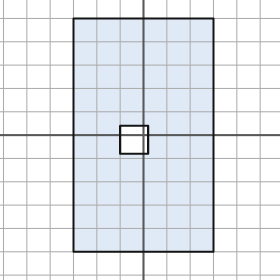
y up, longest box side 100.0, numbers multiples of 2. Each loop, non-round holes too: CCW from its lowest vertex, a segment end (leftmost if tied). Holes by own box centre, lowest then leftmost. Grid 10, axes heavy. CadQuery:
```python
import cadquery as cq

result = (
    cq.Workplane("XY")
    .moveTo(-30.0, -50.0)
    .lineTo(30.0, -50.0)
    .lineTo(30.0, 50.0)
    .lineTo(-30.0, 50.0)
    .close()
    .moveTo(-10.0, -8.0)
    .lineTo(2.0, -8.0)
    .lineTo(2.0, 4.0)
    .lineTo(-10.0, 4.0)
    .close()
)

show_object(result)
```